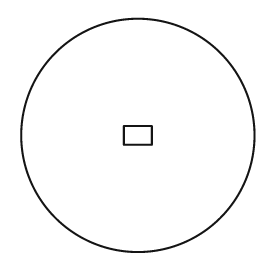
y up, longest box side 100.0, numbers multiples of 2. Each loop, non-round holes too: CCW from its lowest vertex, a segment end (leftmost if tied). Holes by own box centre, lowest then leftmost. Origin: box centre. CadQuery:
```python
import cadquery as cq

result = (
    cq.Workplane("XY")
    .moveTo(0.0, 0.0)
    .circle(50.0)
    .moveTo(-6.0, -4.0)
    .lineTo(6.0, -4.0)
    .lineTo(6.0, 4.0)
    .lineTo(-6.0, 4.0)
    .close()
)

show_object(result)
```